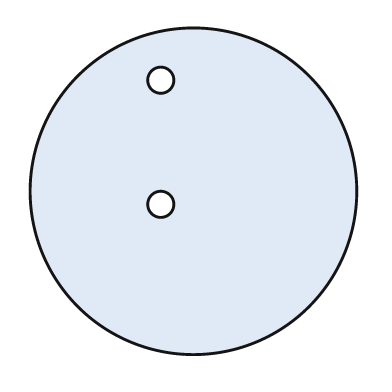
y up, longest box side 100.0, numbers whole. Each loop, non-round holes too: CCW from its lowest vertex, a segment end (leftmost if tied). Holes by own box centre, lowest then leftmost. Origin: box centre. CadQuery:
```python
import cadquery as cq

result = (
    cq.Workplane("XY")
    .moveTo(0.0, 0.0)
    .circle(50.0)
    .moveTo(-10.0, -4.0)
    .circle(4.0)
    .moveTo(-10.0, 34.0)
    .circle(4.0)
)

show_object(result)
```